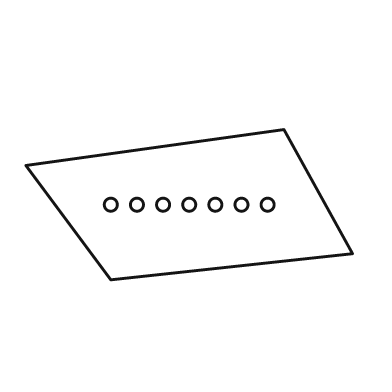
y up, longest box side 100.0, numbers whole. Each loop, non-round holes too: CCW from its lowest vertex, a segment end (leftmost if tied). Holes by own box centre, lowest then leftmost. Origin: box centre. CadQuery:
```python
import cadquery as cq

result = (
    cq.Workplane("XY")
    .moveTo(-24.0, -23.0)
    .lineTo(50.0, -15.0)
    .lineTo(29.0, 23.0)
    .lineTo(-50.0, 12.0)
    .close()
    .moveTo(-24.0, 0.0)
    .circle(2.0)
    .moveTo(-16.0, 0.0)
    .circle(2.0)
    .moveTo(-8.0, 0.0)
    .circle(2.0)
    .moveTo(0.0, 0.0)
    .circle(2.0)
    .moveTo(8.0, 0.0)
    .circle(2.0)
    .moveTo(16.0, 0.0)
    .circle(2.0)
    .moveTo(24.0, 0.0)
    .circle(2.0)
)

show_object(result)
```